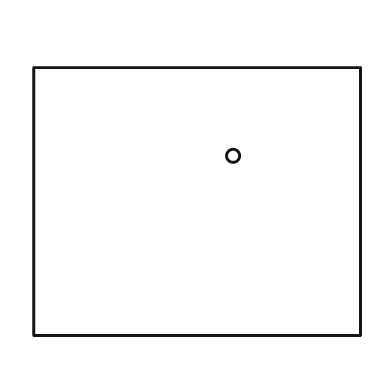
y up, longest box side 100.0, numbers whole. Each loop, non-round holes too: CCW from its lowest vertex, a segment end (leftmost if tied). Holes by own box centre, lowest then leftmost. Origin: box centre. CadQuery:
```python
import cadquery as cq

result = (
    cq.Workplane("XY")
    .moveTo(-50.0, -41.0)
    .lineTo(50.0, -41.0)
    .lineTo(50.0, 41.0)
    .lineTo(-50.0, 41.0)
    .close()
    .moveTo(11.0, 14.0)
    .circle(2.0)
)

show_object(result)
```